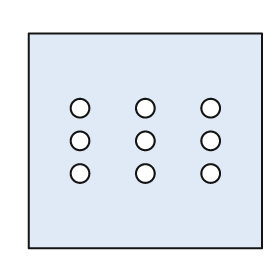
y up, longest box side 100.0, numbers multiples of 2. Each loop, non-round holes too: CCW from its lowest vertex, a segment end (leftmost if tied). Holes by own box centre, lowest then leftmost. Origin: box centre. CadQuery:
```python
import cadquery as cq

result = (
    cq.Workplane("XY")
    .moveTo(-50.0, -46.0)
    .lineTo(50.0, -46.0)
    .lineTo(50.0, 46.0)
    .lineTo(-50.0, 46.0)
    .close()
    .moveTo(-28.0, -14.0)
    .circle(4.0)
    .moveTo(0.0, -14.0)
    .circle(4.0)
    .moveTo(28.0, -14.0)
    .circle(4.0)
    .moveTo(-28.0, 0.0)
    .circle(4.0)
    .moveTo(0.0, 0.0)
    .circle(4.0)
    .moveTo(28.0, 0.0)
    .circle(4.0)
    .moveTo(-28.0, 14.0)
    .circle(4.0)
    .moveTo(0.0, 14.0)
    .circle(4.0)
    .moveTo(28.0, 14.0)
    .circle(4.0)
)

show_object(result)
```